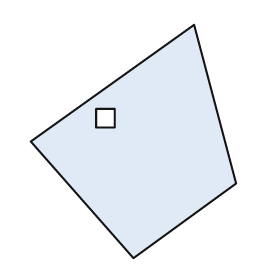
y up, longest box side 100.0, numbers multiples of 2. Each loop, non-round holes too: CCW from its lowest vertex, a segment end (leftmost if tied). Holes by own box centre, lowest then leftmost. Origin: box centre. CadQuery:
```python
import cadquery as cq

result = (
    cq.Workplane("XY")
    .moveTo(0.0, -50.0)
    .lineTo(44.0, -18.0)
    .lineTo(26.0, 50.0)
    .lineTo(-44.0, 0.0)
    .close()
    .moveTo(-16.0, 6.0)
    .lineTo(-8.0, 6.0)
    .lineTo(-8.0, 14.0)
    .lineTo(-16.0, 14.0)
    .close()
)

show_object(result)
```